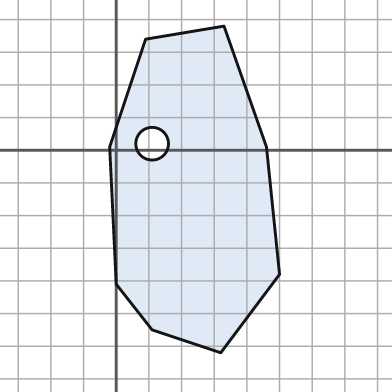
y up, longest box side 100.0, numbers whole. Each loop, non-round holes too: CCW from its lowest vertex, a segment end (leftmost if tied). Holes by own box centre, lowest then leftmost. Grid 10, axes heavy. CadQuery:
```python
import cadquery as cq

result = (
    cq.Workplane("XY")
    .moveTo(32.0, -62.0)
    .lineTo(50.0, -38.0)
    .lineTo(46.0, 1.0)
    .lineTo(33.0, 38.0)
    .lineTo(9.0, 34.0)
    .lineTo(-2.0, 1.0)
    .lineTo(0.0, -41.0)
    .lineTo(11.0, -55.0)
    .close()
    .moveTo(11.0, 2.0)
    .circle(5.0)
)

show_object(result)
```